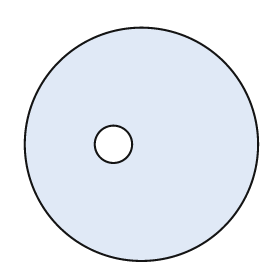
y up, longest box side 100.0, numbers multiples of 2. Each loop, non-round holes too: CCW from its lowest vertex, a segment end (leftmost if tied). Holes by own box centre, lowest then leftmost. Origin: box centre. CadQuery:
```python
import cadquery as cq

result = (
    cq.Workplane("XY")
    .moveTo(0.0, 0.0)
    .circle(50.0)
    .moveTo(-12.0, 0.0)
    .circle(8.0)
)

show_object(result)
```